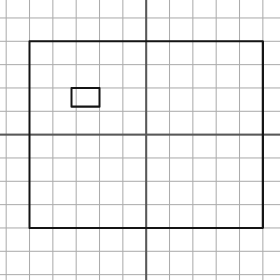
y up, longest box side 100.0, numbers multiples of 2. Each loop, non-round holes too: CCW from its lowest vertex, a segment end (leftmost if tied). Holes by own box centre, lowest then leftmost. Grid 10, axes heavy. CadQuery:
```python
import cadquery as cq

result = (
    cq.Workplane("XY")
    .moveTo(-50.0, -40.0)
    .lineTo(50.0, -40.0)
    .lineTo(50.0, 40.0)
    .lineTo(-50.0, 40.0)
    .close()
    .moveTo(-32.0, 12.0)
    .lineTo(-20.0, 12.0)
    .lineTo(-20.0, 20.0)
    .lineTo(-32.0, 20.0)
    .close()
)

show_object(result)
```